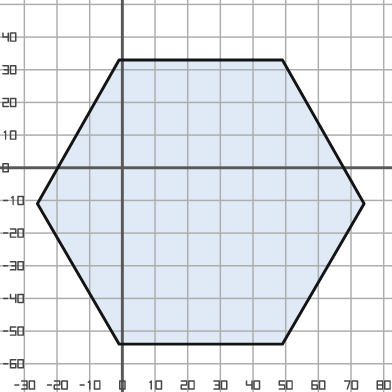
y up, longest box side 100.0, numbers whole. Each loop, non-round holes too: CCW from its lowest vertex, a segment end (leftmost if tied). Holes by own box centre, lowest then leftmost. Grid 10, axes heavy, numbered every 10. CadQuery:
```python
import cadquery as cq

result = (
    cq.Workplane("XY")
    .moveTo(-1.0, -54.0)
    .lineTo(49.0, -54.0)
    .lineTo(74.0, -11.0)
    .lineTo(49.0, 33.0)
    .lineTo(-1.0, 33.0)
    .lineTo(-26.0, -11.0)
    .close()
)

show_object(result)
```